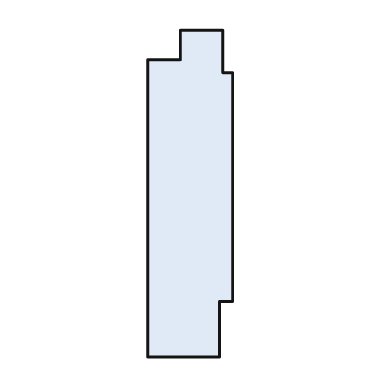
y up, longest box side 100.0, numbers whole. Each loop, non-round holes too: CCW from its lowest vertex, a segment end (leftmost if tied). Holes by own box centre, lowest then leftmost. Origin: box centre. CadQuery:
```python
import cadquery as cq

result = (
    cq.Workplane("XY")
    .moveTo(-13.0, -50.0)
    .lineTo(9.0, -50.0)
    .lineTo(9.0, -33.0)
    .lineTo(13.0, -33.0)
    .lineTo(13.0, 37.0)
    .lineTo(10.0, 37.0)
    .lineTo(10.0, 50.0)
    .lineTo(-3.0, 50.0)
    .lineTo(-3.0, 41.0)
    .lineTo(-13.0, 41.0)
    .close()
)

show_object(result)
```